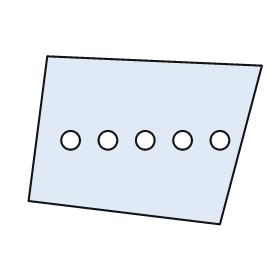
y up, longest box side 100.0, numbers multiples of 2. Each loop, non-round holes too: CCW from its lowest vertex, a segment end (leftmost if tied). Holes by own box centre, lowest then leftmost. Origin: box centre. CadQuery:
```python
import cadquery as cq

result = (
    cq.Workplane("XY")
    .moveTo(32.0, -36.0)
    .lineTo(50.0, 32.0)
    .lineTo(-42.0, 36.0)
    .lineTo(-50.0, -26.0)
    .close()
    .moveTo(-32.0, 0.0)
    .circle(4.0)
    .moveTo(-16.0, 0.0)
    .circle(4.0)
    .moveTo(0.0, 0.0)
    .circle(4.0)
    .moveTo(16.0, 0.0)
    .circle(4.0)
    .moveTo(32.0, 0.0)
    .circle(4.0)
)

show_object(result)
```